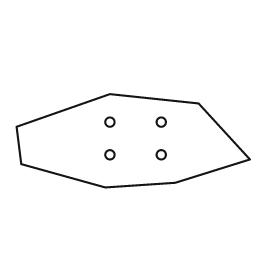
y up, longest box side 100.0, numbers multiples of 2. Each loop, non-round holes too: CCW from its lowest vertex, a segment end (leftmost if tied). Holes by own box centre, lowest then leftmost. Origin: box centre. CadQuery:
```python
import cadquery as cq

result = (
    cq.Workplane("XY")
    .moveTo(-12.0, -20.0)
    .lineTo(18.0, -18.0)
    .lineTo(50.0, -8.0)
    .lineTo(28.0, 16.0)
    .lineTo(-10.0, 20.0)
    .lineTo(-50.0, 6.0)
    .lineTo(-48.0, -10.0)
    .close()
    .moveTo(-10.0, -6.0)
    .circle(2.0)
    .moveTo(12.0, -6.0)
    .circle(2.0)
    .moveTo(-10.0, 8.0)
    .circle(2.0)
    .moveTo(12.0, 8.0)
    .circle(2.0)
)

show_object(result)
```